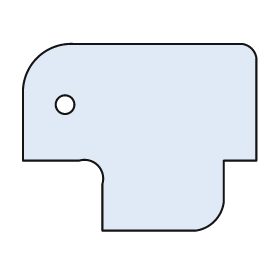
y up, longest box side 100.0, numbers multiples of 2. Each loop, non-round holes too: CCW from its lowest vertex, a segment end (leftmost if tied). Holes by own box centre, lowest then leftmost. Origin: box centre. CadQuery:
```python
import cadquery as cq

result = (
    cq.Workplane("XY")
    .moveTo(-16.0, -40.0)
    .lineTo(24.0, -40.0)
    .threePointArc((32.0, -36.0), (36.0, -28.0))
    .lineTo(36.0, -10.0)
    .lineTo(50.0, -10.0)
    .lineTo(50.0, 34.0)
    .threePointArc((48.0, 38.0), (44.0, 40.0))
    .lineTo(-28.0, 40.0)
    .threePointArc((-44.0, 34.0), (-50.0, 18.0))
    .lineTo(-50.0, -10.0)
    .lineTo(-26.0, -10.0)
    .threePointArc((-18.0, -12.0), (-16.0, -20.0))
    .close()
    .moveTo(-32.0, 14.0)
    .circle(4.0)
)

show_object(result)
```